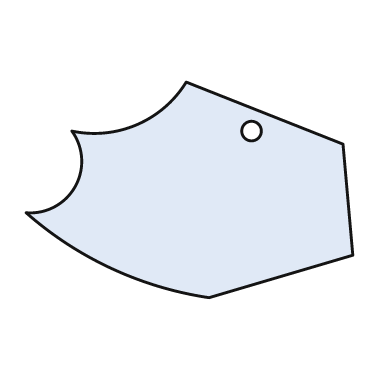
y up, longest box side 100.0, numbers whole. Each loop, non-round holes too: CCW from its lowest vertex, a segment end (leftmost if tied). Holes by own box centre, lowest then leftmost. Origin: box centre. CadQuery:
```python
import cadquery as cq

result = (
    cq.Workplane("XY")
    .moveTo(6.0, -33.0)
    .lineTo(50.0, -20.0)
    .lineTo(47.0, 14.0)
    .lineTo(-1.0, 33.0)
    .threePointArc((-16.0, 20.0), (-36.0, 18.0))
    .threePointArc((-35.0, 1.0), (-50.0, -7.0))
    .threePointArc((-24.0, -24.0), (6.0, -33.0))
    .close()
    .moveTo(19.0, 18.0)
    .circle(3.0)
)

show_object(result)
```